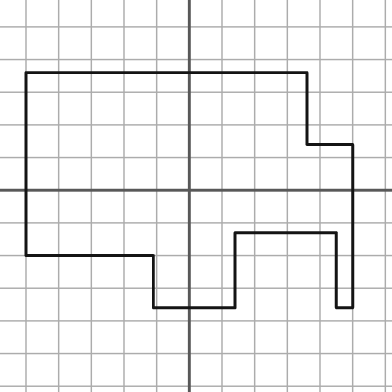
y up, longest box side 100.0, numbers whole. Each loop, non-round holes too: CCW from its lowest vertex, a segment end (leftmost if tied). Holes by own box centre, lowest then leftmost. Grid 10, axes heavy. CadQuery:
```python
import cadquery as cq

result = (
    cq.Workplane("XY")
    .moveTo(-11.0, -36.0)
    .lineTo(14.0, -36.0)
    .lineTo(14.0, -13.0)
    .lineTo(45.0, -13.0)
    .lineTo(45.0, -36.0)
    .lineTo(50.0, -36.0)
    .lineTo(50.0, 14.0)
    .lineTo(36.0, 14.0)
    .lineTo(36.0, 36.0)
    .lineTo(-50.0, 36.0)
    .lineTo(-50.0, -20.0)
    .lineTo(-11.0, -20.0)
    .close()
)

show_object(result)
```